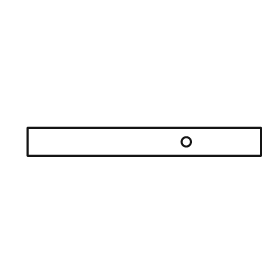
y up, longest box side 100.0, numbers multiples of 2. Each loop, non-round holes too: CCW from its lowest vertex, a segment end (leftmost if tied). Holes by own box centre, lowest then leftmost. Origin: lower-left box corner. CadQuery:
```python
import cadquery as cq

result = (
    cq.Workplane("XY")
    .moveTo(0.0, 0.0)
    .lineTo(100.0, 0.0)
    .lineTo(100.0, 12.0)
    .lineTo(0.0, 12.0)
    .close()
    .moveTo(68.0, 6.0)
    .circle(2.0)
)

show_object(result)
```